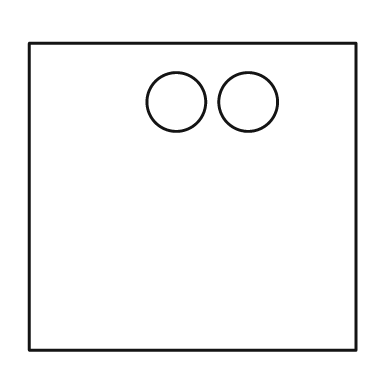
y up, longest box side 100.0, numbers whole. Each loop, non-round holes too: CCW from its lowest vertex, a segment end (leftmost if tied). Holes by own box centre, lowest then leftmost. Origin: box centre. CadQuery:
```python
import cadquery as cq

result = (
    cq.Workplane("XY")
    .moveTo(-50.0, -47.0)
    .lineTo(50.0, -47.0)
    .lineTo(50.0, 47.0)
    .lineTo(-50.0, 47.0)
    .close()
    .moveTo(-5.0, 29.0)
    .circle(9.0)
    .moveTo(17.0, 29.0)
    .circle(9.0)
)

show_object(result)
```